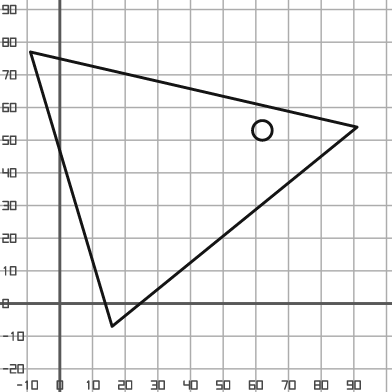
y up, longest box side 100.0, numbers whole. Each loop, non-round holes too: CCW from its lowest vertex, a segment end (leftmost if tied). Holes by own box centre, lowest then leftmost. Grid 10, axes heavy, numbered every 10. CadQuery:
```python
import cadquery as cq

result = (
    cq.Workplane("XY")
    .moveTo(16.0, -7.0)
    .lineTo(91.0, 54.0)
    .lineTo(-9.0, 77.0)
    .close()
    .moveTo(62.0, 53.0)
    .circle(3.0)
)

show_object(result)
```